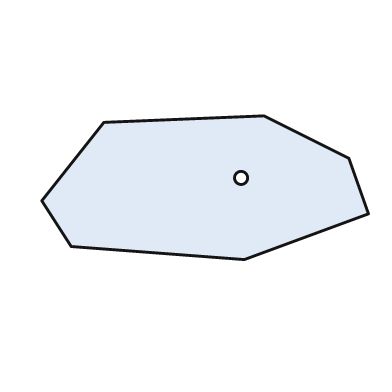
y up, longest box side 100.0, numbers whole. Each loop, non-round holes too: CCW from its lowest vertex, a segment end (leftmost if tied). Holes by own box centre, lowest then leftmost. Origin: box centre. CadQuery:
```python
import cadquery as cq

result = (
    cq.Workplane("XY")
    .moveTo(12.0, -22.0)
    .lineTo(50.0, -8.0)
    .lineTo(44.0, 9.0)
    .lineTo(18.0, 22.0)
    .lineTo(-31.0, 20.0)
    .lineTo(-50.0, -4.0)
    .lineTo(-41.0, -18.0)
    .close()
    .moveTo(11.0, 3.0)
    .circle(2.0)
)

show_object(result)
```